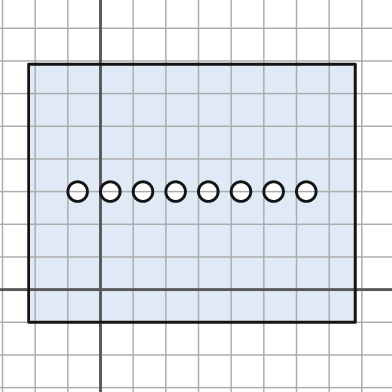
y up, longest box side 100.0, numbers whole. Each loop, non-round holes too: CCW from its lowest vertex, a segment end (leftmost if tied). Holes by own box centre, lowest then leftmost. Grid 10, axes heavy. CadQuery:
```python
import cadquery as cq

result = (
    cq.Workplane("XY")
    .moveTo(-22.0, -10.0)
    .lineTo(78.0, -10.0)
    .lineTo(78.0, 69.0)
    .lineTo(-22.0, 69.0)
    .close()
    .moveTo(-7.0, 30.0)
    .circle(3.0)
    .moveTo(3.0, 30.0)
    .circle(3.0)
    .moveTo(13.0, 30.0)
    .circle(3.0)
    .moveTo(23.0, 30.0)
    .circle(3.0)
    .moveTo(33.0, 30.0)
    .circle(3.0)
    .moveTo(43.0, 30.0)
    .circle(3.0)
    .moveTo(53.0, 30.0)
    .circle(3.0)
    .moveTo(63.0, 30.0)
    .circle(3.0)
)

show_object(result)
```